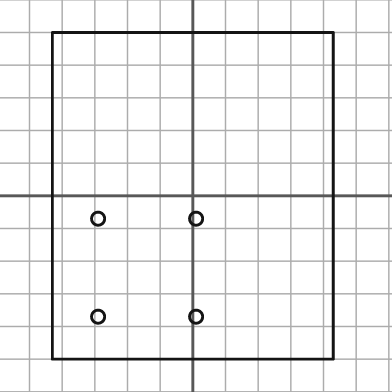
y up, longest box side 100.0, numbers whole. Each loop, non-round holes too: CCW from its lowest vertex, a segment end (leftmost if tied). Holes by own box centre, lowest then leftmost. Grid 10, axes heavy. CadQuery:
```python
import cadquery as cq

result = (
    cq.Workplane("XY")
    .moveTo(-43.0, -50.0)
    .lineTo(43.0, -50.0)
    .lineTo(43.0, 50.0)
    .lineTo(-43.0, 50.0)
    .close()
    .moveTo(-29.0, -37.0)
    .circle(2.0)
    .moveTo(1.0, -37.0)
    .circle(2.0)
    .moveTo(-29.0, -7.0)
    .circle(2.0)
    .moveTo(1.0, -7.0)
    .circle(2.0)
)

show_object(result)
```